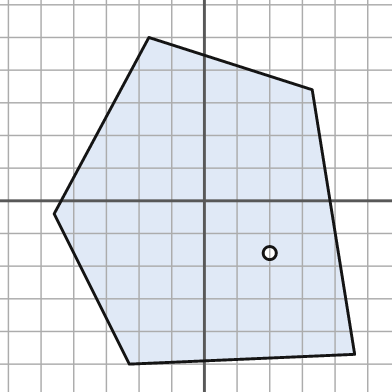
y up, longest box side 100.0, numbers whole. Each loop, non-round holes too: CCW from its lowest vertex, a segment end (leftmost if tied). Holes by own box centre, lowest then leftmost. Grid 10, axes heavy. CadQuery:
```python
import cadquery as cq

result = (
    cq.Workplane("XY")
    .moveTo(-23.0, -50.0)
    .lineTo(46.0, -47.0)
    .lineTo(33.0, 34.0)
    .lineTo(-17.0, 50.0)
    .lineTo(-46.0, -4.0)
    .close()
    .moveTo(20.0, -16.0)
    .circle(2.0)
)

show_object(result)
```